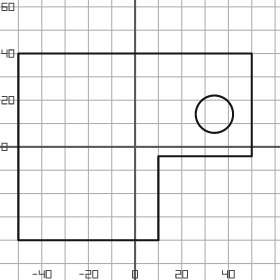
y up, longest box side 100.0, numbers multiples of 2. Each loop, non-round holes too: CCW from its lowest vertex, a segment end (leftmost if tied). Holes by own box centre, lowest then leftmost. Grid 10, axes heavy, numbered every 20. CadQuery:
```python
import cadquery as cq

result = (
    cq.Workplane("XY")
    .moveTo(-50.0, -40.0)
    .lineTo(10.0, -40.0)
    .lineTo(10.0, -4.0)
    .lineTo(50.0, -4.0)
    .lineTo(50.0, 40.0)
    .lineTo(-50.0, 40.0)
    .close()
    .moveTo(34.0, 14.0)
    .circle(8.0)
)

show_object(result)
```